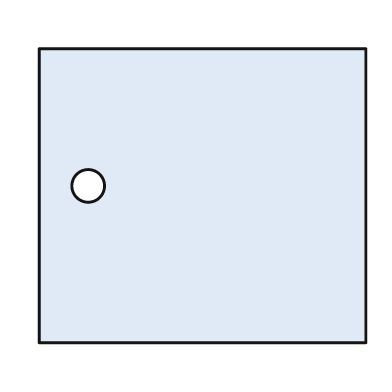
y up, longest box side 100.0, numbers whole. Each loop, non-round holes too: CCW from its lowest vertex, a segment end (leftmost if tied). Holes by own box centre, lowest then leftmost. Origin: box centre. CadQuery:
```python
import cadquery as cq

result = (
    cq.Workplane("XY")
    .moveTo(-50.0, -45.0)
    .lineTo(50.0, -45.0)
    .lineTo(50.0, 45.0)
    .lineTo(-50.0, 45.0)
    .close()
    .moveTo(-35.0, 3.0)
    .circle(5.0)
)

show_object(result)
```